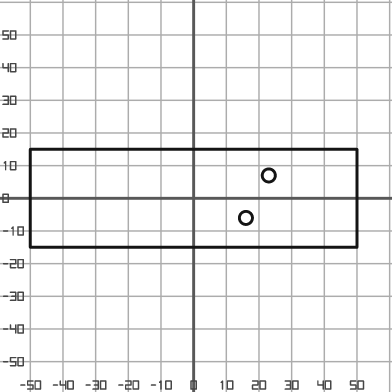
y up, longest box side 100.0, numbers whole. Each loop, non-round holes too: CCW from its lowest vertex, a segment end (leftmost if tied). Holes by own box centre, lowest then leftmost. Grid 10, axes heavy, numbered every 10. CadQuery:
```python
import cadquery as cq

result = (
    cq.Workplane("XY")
    .moveTo(-50.0, -15.0)
    .lineTo(50.0, -15.0)
    .lineTo(50.0, 15.0)
    .lineTo(-50.0, 15.0)
    .close()
    .moveTo(16.0, -6.0)
    .circle(2.0)
    .moveTo(23.0, 7.0)
    .circle(2.0)
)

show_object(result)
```